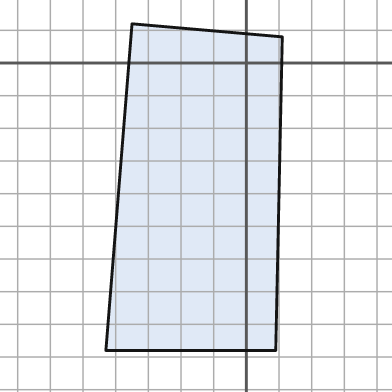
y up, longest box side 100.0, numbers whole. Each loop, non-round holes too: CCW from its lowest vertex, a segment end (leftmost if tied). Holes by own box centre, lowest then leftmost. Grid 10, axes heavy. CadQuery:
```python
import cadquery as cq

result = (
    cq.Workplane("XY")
    .moveTo(-43.0, -88.0)
    .lineTo(9.0, -88.0)
    .lineTo(11.0, 8.0)
    .lineTo(-35.0, 12.0)
    .close()
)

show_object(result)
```